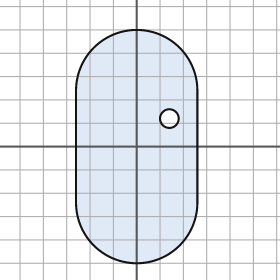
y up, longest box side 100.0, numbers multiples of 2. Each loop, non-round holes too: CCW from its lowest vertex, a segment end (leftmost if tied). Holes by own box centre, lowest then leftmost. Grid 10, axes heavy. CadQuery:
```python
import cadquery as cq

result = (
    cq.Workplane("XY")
    .moveTo(-26.0, -24.0)
    .threePointArc((0.0, -50.0), (26.0, -24.0))
    .lineTo(26.0, 24.0)
    .threePointArc((0.0, 50.0), (-26.0, 24.0))
    .close()
    .moveTo(14.0, 12.0)
    .circle(4.0)
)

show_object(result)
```